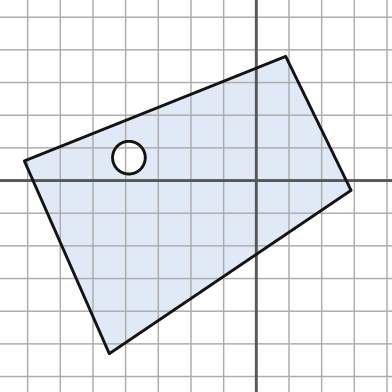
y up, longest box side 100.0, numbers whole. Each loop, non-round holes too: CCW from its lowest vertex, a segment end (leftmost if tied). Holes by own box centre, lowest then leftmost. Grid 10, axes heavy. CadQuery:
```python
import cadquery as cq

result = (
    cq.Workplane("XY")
    .moveTo(-45.0, -53.0)
    .lineTo(29.0, -3.0)
    .lineTo(9.0, 38.0)
    .lineTo(-71.0, 6.0)
    .close()
    .moveTo(-39.0, 7.0)
    .circle(5.0)
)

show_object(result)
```